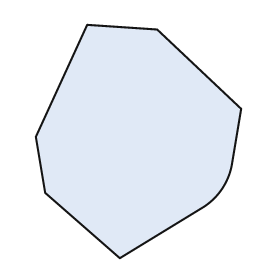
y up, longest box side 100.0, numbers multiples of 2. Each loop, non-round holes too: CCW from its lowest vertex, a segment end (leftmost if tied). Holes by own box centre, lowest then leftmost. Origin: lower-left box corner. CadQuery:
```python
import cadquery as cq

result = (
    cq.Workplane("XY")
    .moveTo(36.0, 0.0)
    .lineTo(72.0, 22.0)
    .threePointArc((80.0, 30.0), (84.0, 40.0))
    .lineTo(88.0, 64.0)
    .lineTo(52.0, 98.0)
    .lineTo(22.0, 100.0)
    .lineTo(0.0, 52.0)
    .lineTo(4.0, 28.0)
    .close()
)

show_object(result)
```